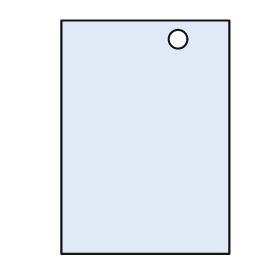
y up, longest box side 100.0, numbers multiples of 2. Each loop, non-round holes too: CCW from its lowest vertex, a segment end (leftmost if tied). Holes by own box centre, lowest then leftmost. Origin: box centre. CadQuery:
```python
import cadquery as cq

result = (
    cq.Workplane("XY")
    .moveTo(-36.0, -50.0)
    .lineTo(36.0, -50.0)
    .lineTo(36.0, 50.0)
    .lineTo(-36.0, 50.0)
    .close()
    .moveTo(14.0, 42.0)
    .circle(4.0)
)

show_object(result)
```